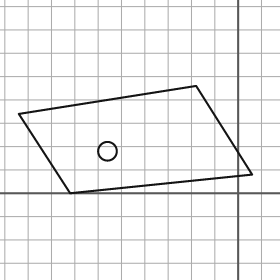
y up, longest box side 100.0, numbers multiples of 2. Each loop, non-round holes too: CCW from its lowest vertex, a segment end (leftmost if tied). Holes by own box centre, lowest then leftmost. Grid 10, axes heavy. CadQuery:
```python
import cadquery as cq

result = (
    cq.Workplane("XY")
    .moveTo(-72.0, 0.0)
    .lineTo(6.0, 8.0)
    .lineTo(-18.0, 46.0)
    .lineTo(-94.0, 34.0)
    .close()
    .moveTo(-56.0, 18.0)
    .circle(4.0)
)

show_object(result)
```